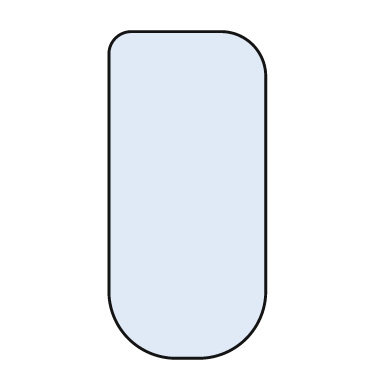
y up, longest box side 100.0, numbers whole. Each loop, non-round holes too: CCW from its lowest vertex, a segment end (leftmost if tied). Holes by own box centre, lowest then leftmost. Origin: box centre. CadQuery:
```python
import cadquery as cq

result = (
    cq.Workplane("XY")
    .moveTo(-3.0, -50.0)
    .lineTo(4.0, -50.0)
    .threePointArc((18.0, -44.0), (24.0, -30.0))
    .lineTo(24.0, 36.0)
    .threePointArc((20.0, 46.0), (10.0, 50.0))
    .lineTo(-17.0, 50.0)
    .threePointArc((-22.0, 48.0), (-24.0, 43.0))
    .lineTo(-24.0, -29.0)
    .threePointArc((-18.0, -44.0), (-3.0, -50.0))
    .close()
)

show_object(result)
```